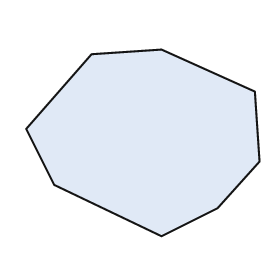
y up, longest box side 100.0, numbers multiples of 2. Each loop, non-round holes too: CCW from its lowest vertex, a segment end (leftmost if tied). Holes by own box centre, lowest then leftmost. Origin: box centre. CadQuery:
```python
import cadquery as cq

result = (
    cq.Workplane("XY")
    .moveTo(8.0, -40.0)
    .lineTo(32.0, -28.0)
    .lineTo(50.0, -8.0)
    .lineTo(48.0, 22.0)
    .lineTo(8.0, 40.0)
    .lineTo(-22.0, 38.0)
    .lineTo(-50.0, 6.0)
    .lineTo(-38.0, -18.0)
    .close()
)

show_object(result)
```